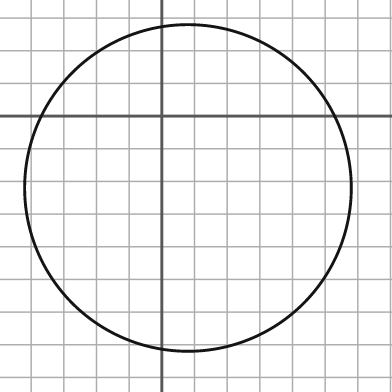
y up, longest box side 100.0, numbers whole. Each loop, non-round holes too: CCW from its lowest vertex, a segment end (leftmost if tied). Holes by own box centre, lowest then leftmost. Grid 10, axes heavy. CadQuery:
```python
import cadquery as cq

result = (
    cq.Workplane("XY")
    .moveTo(8.0, -22.0)
    .circle(50.0)
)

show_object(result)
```